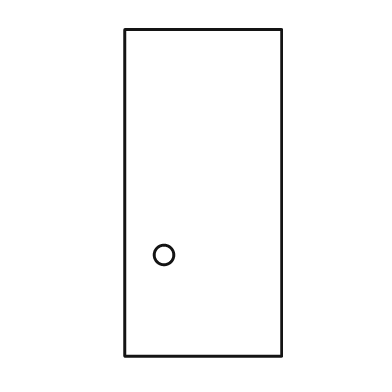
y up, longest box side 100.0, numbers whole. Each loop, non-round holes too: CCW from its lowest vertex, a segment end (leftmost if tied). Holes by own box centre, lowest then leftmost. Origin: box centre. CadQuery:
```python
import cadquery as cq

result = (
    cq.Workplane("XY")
    .moveTo(-24.0, -50.0)
    .lineTo(24.0, -50.0)
    .lineTo(24.0, 50.0)
    .lineTo(-24.0, 50.0)
    .close()
    .moveTo(-12.0, -19.0)
    .circle(3.0)
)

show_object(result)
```